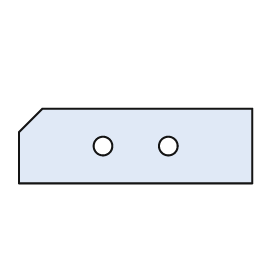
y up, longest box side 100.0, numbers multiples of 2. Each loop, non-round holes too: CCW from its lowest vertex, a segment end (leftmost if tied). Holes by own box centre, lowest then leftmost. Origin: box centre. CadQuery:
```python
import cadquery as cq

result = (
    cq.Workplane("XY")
    .moveTo(-50.0, -16.0)
    .lineTo(50.0, -16.0)
    .lineTo(50.0, 16.0)
    .lineTo(-40.0, 16.0)
    .lineTo(-50.0, 6.0)
    .close()
    .moveTo(-14.0, 0.0)
    .circle(4.0)
    .moveTo(14.0, 0.0)
    .circle(4.0)
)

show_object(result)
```